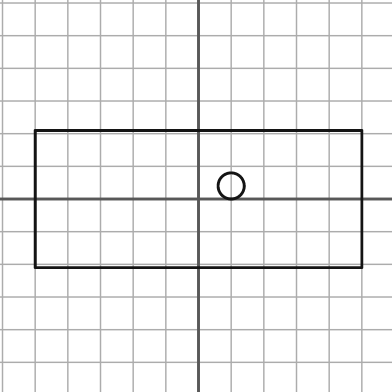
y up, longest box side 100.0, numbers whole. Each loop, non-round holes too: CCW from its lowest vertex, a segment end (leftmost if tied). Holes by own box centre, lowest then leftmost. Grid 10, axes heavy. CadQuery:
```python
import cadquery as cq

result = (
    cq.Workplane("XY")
    .moveTo(-50.0, -21.0)
    .lineTo(50.0, -21.0)
    .lineTo(50.0, 21.0)
    .lineTo(-50.0, 21.0)
    .close()
    .moveTo(10.0, 4.0)
    .circle(4.0)
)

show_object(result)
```